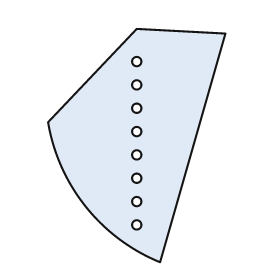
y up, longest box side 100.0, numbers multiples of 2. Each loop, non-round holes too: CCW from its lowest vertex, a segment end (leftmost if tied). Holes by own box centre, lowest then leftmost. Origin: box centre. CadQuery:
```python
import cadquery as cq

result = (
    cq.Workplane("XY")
    .moveTo(10.0, -50.0)
    .lineTo(38.0, 48.0)
    .lineTo(0.0, 50.0)
    .lineTo(-38.0, 10.0)
    .threePointArc((-22.0, -26.0), (10.0, -50.0))
    .close()
    .moveTo(0.0, -34.0)
    .circle(2.0)
    .moveTo(0.0, -24.0)
    .circle(2.0)
    .moveTo(0.0, -14.0)
    .circle(2.0)
    .moveTo(0.0, -4.0)
    .circle(2.0)
    .moveTo(0.0, 6.0)
    .circle(2.0)
    .moveTo(0.0, 16.0)
    .circle(2.0)
    .moveTo(0.0, 26.0)
    .circle(2.0)
    .moveTo(0.0, 36.0)
    .circle(2.0)
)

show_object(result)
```